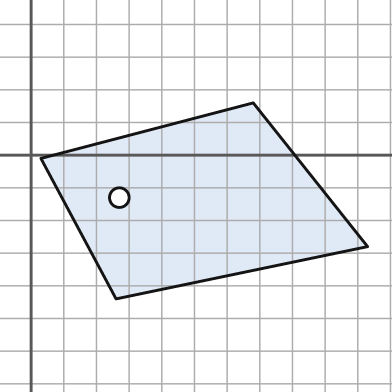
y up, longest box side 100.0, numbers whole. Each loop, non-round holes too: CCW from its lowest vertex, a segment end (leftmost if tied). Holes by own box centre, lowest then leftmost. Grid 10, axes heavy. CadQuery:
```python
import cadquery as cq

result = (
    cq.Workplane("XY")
    .moveTo(26.0, -44.0)
    .lineTo(103.0, -28.0)
    .lineTo(68.0, 16.0)
    .lineTo(3.0, -1.0)
    .close()
    .moveTo(27.0, -13.0)
    .circle(3.0)
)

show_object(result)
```